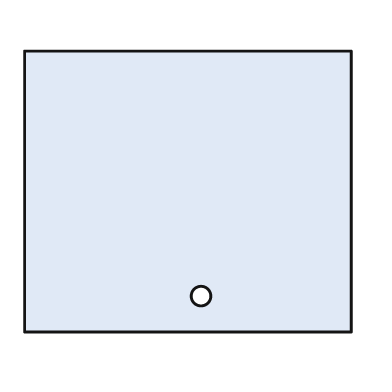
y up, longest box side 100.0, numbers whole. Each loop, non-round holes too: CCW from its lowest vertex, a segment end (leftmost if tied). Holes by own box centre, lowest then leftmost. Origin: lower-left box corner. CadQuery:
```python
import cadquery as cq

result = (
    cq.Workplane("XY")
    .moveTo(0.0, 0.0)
    .lineTo(100.0, 0.0)
    .lineTo(100.0, 86.0)
    .lineTo(0.0, 86.0)
    .close()
    .moveTo(54.0, 11.0)
    .circle(3.0)
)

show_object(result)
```